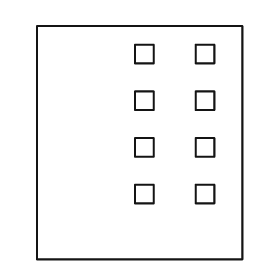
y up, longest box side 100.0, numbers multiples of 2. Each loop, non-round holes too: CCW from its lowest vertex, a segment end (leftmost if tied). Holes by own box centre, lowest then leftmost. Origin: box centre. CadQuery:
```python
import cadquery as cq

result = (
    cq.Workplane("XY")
    .moveTo(-44.0, -50.0)
    .lineTo(44.0, -50.0)
    .lineTo(44.0, 50.0)
    .lineTo(-44.0, 50.0)
    .close()
    .moveTo(-2.0, -26.0)
    .lineTo(6.0, -26.0)
    .lineTo(6.0, -18.0)
    .lineTo(-2.0, -18.0)
    .close()
    .moveTo(24.0, -26.0)
    .lineTo(32.0, -26.0)
    .lineTo(32.0, -18.0)
    .lineTo(24.0, -18.0)
    .close()
    .moveTo(-2.0, -6.0)
    .lineTo(6.0, -6.0)
    .lineTo(6.0, 2.0)
    .lineTo(-2.0, 2.0)
    .close()
    .moveTo(24.0, -6.0)
    .lineTo(32.0, -6.0)
    .lineTo(32.0, 2.0)
    .lineTo(24.0, 2.0)
    .close()
    .moveTo(-2.0, 14.0)
    .lineTo(6.0, 14.0)
    .lineTo(6.0, 22.0)
    .lineTo(-2.0, 22.0)
    .close()
    .moveTo(24.0, 14.0)
    .lineTo(32.0, 14.0)
    .lineTo(32.0, 22.0)
    .lineTo(24.0, 22.0)
    .close()
    .moveTo(-2.0, 34.0)
    .lineTo(6.0, 34.0)
    .lineTo(6.0, 42.0)
    .lineTo(-2.0, 42.0)
    .close()
    .moveTo(24.0, 34.0)
    .lineTo(32.0, 34.0)
    .lineTo(32.0, 42.0)
    .lineTo(24.0, 42.0)
    .close()
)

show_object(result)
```